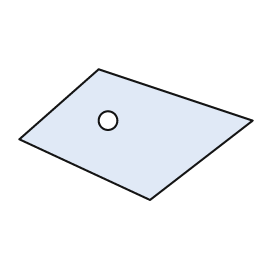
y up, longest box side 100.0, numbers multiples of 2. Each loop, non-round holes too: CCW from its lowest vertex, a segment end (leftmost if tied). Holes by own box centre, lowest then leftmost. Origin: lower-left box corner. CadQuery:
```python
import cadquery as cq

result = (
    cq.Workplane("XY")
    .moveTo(56.0, 0.0)
    .lineTo(100.0, 34.0)
    .lineTo(34.0, 56.0)
    .lineTo(0.0, 26.0)
    .close()
    .moveTo(38.0, 34.0)
    .circle(4.0)
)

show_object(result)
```